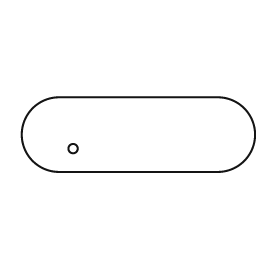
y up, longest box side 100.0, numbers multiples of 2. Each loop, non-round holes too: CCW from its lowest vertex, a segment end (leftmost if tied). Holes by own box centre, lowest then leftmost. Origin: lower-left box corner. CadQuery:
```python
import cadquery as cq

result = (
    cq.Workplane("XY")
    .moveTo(16.0, 0.0)
    .lineTo(84.0, 0.0)
    .threePointArc((100.0, 16.0), (84.0, 32.0))
    .lineTo(16.0, 32.0)
    .threePointArc((0.0, 16.0), (16.0, 0.0))
    .close()
    .moveTo(22.0, 10.0)
    .circle(2.0)
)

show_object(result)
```